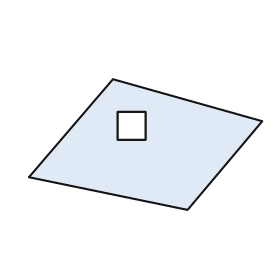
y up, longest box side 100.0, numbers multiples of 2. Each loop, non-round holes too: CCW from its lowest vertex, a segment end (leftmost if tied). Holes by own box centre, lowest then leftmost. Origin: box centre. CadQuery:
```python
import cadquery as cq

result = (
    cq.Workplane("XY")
    .moveTo(18.0, -28.0)
    .lineTo(50.0, 10.0)
    .lineTo(-14.0, 28.0)
    .lineTo(-50.0, -14.0)
    .close()
    .moveTo(-12.0, 2.0)
    .lineTo(0.0, 2.0)
    .lineTo(0.0, 14.0)
    .lineTo(-12.0, 14.0)
    .close()
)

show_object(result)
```